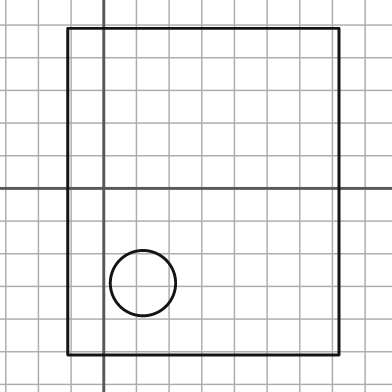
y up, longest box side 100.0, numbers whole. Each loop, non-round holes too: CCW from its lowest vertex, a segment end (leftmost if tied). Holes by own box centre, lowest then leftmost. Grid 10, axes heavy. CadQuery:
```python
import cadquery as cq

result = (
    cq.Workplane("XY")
    .moveTo(-11.0, -51.0)
    .lineTo(72.0, -51.0)
    .lineTo(72.0, 49.0)
    .lineTo(-11.0, 49.0)
    .close()
    .moveTo(12.0, -29.0)
    .circle(10.0)
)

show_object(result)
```